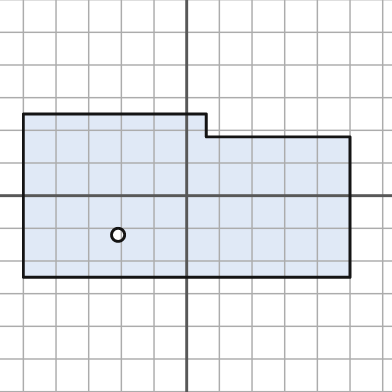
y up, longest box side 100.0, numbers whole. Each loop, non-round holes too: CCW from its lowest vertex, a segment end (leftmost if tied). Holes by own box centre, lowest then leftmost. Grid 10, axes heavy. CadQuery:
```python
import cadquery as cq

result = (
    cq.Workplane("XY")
    .moveTo(-50.0, -25.0)
    .lineTo(50.0, -25.0)
    .lineTo(50.0, 18.0)
    .lineTo(6.0, 18.0)
    .lineTo(6.0, 25.0)
    .lineTo(-50.0, 25.0)
    .close()
    .moveTo(-21.0, -12.0)
    .circle(2.0)
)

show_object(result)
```